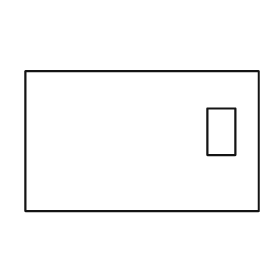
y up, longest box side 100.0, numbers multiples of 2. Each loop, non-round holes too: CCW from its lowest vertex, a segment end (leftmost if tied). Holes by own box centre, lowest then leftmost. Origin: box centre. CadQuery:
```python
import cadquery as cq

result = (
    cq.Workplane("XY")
    .moveTo(-50.0, -30.0)
    .lineTo(50.0, -30.0)
    .lineTo(50.0, 30.0)
    .lineTo(-50.0, 30.0)
    .close()
    .moveTo(28.0, -6.0)
    .lineTo(40.0, -6.0)
    .lineTo(40.0, 14.0)
    .lineTo(28.0, 14.0)
    .close()
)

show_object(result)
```